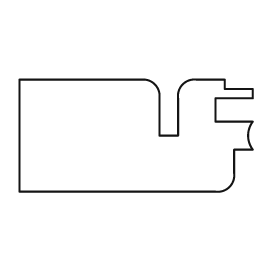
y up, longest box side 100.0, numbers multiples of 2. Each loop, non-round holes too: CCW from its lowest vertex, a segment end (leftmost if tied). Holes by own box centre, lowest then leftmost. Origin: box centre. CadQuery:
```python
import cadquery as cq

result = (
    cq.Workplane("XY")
    .moveTo(-50.0, -24.0)
    .lineTo(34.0, -24.0)
    .threePointArc((40.0, -22.0), (42.0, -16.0))
    .lineTo(42.0, -6.0)
    .lineTo(50.0, -6.0)
    .threePointArc((48.0, 0.0), (50.0, 6.0))
    .lineTo(34.0, 6.0)
    .lineTo(34.0, 16.0)
    .lineTo(50.0, 16.0)
    .lineTo(50.0, 20.0)
    .lineTo(38.0, 20.0)
    .lineTo(38.0, 24.0)
    .lineTo(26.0, 24.0)
    .threePointArc((20.0, 22.0), (18.0, 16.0))
    .lineTo(18.0, 0.0)
    .lineTo(10.0, 0.0)
    .lineTo(10.0, 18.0)
    .threePointArc((8.0, 22.0), (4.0, 24.0))
    .lineTo(-50.0, 24.0)
    .close()
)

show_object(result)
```